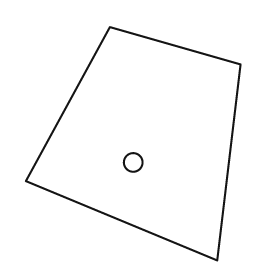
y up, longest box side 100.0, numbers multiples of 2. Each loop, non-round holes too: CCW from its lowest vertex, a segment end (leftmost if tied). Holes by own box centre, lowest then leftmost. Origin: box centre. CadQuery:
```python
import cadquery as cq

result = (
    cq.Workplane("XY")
    .moveTo(36.0, -50.0)
    .lineTo(46.0, 34.0)
    .lineTo(-10.0, 50.0)
    .lineTo(-46.0, -16.0)
    .close()
    .moveTo(0.0, -8.0)
    .circle(4.0)
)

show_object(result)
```